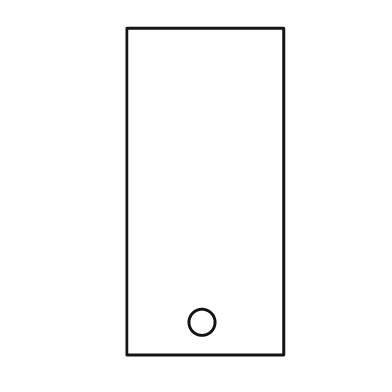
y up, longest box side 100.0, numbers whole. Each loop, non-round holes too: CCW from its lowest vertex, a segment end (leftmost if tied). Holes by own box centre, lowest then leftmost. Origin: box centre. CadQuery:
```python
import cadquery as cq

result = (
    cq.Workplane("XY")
    .moveTo(-24.0, -50.0)
    .lineTo(24.0, -50.0)
    .lineTo(24.0, 50.0)
    .lineTo(-24.0, 50.0)
    .close()
    .moveTo(-1.0, -40.0)
    .circle(4.0)
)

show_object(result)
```